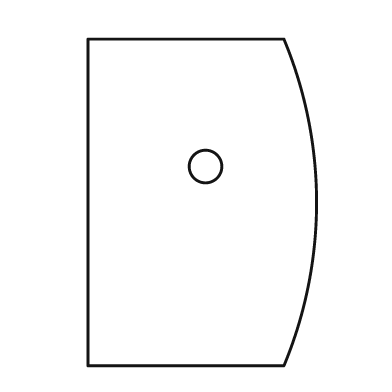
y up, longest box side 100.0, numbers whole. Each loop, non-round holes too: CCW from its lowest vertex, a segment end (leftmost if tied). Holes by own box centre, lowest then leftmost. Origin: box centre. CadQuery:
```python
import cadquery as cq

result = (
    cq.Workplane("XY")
    .moveTo(-35.0, -50.0)
    .lineTo(25.0, -50.0)
    .threePointArc((35.0, 0.0), (25.0, 50.0))
    .lineTo(-35.0, 50.0)
    .close()
    .moveTo(1.0, 11.0)
    .circle(5.0)
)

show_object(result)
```